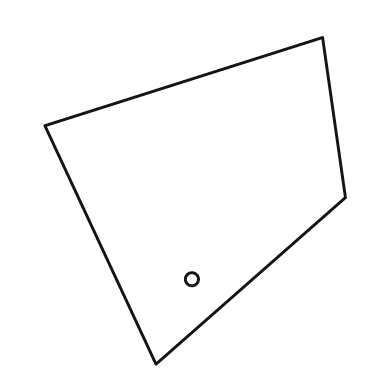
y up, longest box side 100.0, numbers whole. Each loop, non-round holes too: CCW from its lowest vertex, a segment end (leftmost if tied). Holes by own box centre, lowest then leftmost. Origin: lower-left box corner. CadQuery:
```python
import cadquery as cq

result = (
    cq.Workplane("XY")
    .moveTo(34.0, 0.0)
    .lineTo(92.0, 51.0)
    .lineTo(85.0, 100.0)
    .lineTo(0.0, 73.0)
    .close()
    .moveTo(45.0, 26.0)
    .circle(2.0)
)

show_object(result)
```